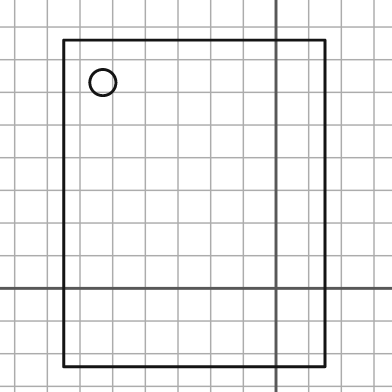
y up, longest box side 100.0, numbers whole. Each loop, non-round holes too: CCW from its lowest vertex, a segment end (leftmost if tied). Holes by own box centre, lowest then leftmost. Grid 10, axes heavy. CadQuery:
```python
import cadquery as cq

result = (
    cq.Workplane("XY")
    .moveTo(-65.0, -24.0)
    .lineTo(15.0, -24.0)
    .lineTo(15.0, 76.0)
    .lineTo(-65.0, 76.0)
    .close()
    .moveTo(-53.0, 63.0)
    .circle(4.0)
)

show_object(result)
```